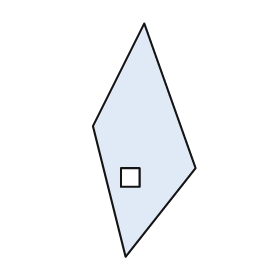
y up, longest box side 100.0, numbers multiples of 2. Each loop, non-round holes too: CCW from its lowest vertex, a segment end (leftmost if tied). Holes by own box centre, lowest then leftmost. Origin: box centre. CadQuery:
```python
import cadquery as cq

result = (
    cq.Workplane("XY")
    .moveTo(-8.0, -50.0)
    .lineTo(22.0, -12.0)
    .lineTo(0.0, 50.0)
    .lineTo(-22.0, 6.0)
    .close()
    .moveTo(-10.0, -20.0)
    .lineTo(-2.0, -20.0)
    .lineTo(-2.0, -12.0)
    .lineTo(-10.0, -12.0)
    .close()
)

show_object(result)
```